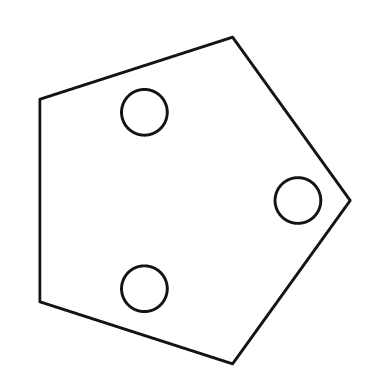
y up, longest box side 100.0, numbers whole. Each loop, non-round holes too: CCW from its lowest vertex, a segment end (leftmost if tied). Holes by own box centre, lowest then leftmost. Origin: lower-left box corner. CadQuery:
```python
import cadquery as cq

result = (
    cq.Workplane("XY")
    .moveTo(59.0, 0.0)
    .lineTo(95.0, 50.0)
    .lineTo(59.0, 100.0)
    .lineTo(0.0, 81.0)
    .lineTo(0.0, 19.0)
    .close()
    .moveTo(32.0, 23.0)
    .circle(7.0)
    .moveTo(79.0, 50.0)
    .circle(7.0)
    .moveTo(32.0, 77.0)
    .circle(7.0)
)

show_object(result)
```